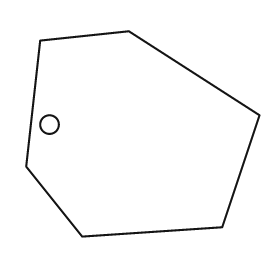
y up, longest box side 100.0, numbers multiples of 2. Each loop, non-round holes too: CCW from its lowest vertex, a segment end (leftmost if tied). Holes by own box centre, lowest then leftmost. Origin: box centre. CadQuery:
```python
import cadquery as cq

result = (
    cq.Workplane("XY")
    .moveTo(-26.0, -44.0)
    .lineTo(34.0, -40.0)
    .lineTo(50.0, 8.0)
    .lineTo(-6.0, 44.0)
    .lineTo(-44.0, 40.0)
    .lineTo(-50.0, -14.0)
    .close()
    .moveTo(-40.0, 4.0)
    .circle(4.0)
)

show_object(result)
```